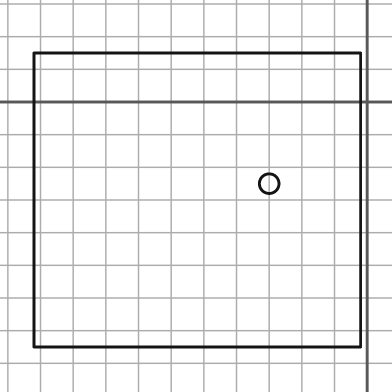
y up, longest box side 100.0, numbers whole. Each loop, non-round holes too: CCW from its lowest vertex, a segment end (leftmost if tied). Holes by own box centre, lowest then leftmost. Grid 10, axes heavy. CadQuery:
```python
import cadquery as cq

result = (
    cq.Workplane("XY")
    .moveTo(-102.0, -75.0)
    .lineTo(-2.0, -75.0)
    .lineTo(-2.0, 15.0)
    .lineTo(-102.0, 15.0)
    .close()
    .moveTo(-30.0, -25.0)
    .circle(3.0)
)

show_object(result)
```